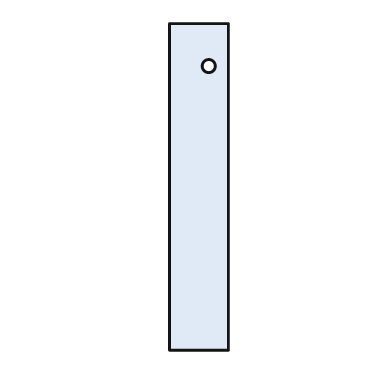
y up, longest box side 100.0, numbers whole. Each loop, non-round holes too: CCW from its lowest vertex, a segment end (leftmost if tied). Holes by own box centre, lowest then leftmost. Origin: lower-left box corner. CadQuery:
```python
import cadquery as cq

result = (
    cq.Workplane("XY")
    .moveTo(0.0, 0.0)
    .lineTo(18.0, 0.0)
    .lineTo(18.0, 100.0)
    .lineTo(0.0, 100.0)
    .close()
    .moveTo(12.0, 87.0)
    .circle(2.0)
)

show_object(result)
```